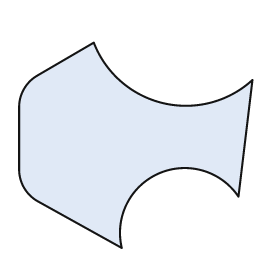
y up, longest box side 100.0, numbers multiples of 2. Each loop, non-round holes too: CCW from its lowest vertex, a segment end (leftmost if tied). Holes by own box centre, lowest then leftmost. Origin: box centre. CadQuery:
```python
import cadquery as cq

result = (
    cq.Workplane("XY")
    .moveTo(-6.0, -44.0)
    .threePointArc((10.0, -12.0), (44.0, -22.0))
    .lineTo(50.0, 28.0)
    .threePointArc((12.0, 18.0), (-18.0, 44.0))
    .lineTo(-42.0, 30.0)
    .threePointArc((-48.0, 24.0), (-50.0, 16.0))
    .lineTo(-50.0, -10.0)
    .threePointArc((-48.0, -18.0), (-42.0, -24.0))
    .close()
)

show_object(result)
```